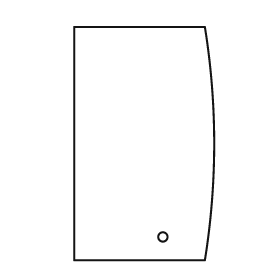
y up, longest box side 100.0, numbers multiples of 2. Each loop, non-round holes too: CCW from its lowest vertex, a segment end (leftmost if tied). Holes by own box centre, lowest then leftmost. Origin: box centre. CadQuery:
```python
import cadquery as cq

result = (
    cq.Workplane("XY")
    .moveTo(-30.0, -50.0)
    .lineTo(26.0, -50.0)
    .threePointArc((30.0, 0.0), (26.0, 50.0))
    .lineTo(-30.0, 50.0)
    .close()
    .moveTo(8.0, -40.0)
    .circle(2.0)
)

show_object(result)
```